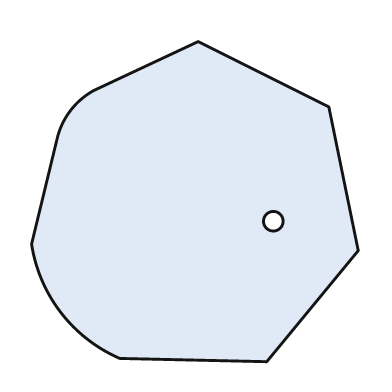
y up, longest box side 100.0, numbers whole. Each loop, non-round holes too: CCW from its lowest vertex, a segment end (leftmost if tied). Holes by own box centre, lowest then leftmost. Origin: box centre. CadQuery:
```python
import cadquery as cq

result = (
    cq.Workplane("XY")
    .moveTo(22.0, -49.0)
    .lineTo(50.0, -15.0)
    .lineTo(41.0, 29.0)
    .lineTo(1.0, 49.0)
    .lineTo(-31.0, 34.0)
    .threePointArc((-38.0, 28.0), (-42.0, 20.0))
    .lineTo(-50.0, -13.0)
    .threePointArc((-41.0, -34.0), (-23.0, -48.0))
    .close()
    .moveTo(24.0, -6.0)
    .circle(3.0)
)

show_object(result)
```